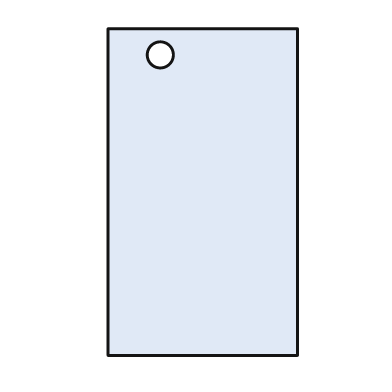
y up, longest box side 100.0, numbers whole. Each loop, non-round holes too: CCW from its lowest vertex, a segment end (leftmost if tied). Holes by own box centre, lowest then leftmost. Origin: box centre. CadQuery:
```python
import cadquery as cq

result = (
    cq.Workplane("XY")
    .moveTo(-29.0, -50.0)
    .lineTo(29.0, -50.0)
    .lineTo(29.0, 50.0)
    .lineTo(-29.0, 50.0)
    .close()
    .moveTo(-13.0, 42.0)
    .circle(4.0)
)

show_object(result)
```